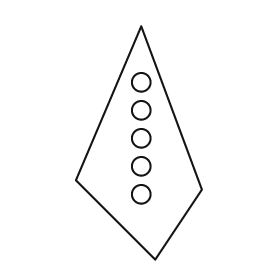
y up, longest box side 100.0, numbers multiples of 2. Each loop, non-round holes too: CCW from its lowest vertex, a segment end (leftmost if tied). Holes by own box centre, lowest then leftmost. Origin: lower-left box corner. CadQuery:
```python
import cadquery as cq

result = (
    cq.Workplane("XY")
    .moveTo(34.0, 0.0)
    .lineTo(54.0, 30.0)
    .lineTo(28.0, 100.0)
    .lineTo(0.0, 34.0)
    .close()
    .moveTo(28.0, 28.0)
    .circle(4.0)
    .moveTo(28.0, 40.0)
    .circle(4.0)
    .moveTo(28.0, 52.0)
    .circle(4.0)
    .moveTo(28.0, 64.0)
    .circle(4.0)
    .moveTo(28.0, 76.0)
    .circle(4.0)
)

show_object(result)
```